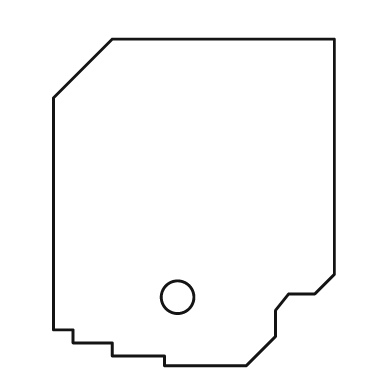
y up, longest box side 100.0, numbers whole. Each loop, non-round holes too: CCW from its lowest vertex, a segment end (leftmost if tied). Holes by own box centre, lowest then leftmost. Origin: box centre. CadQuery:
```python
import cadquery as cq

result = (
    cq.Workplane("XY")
    .moveTo(-9.0, -50.0)
    .lineTo(16.0, -50.0)
    .lineTo(25.0, -41.0)
    .lineTo(25.0, -33.0)
    .lineTo(29.0, -28.0)
    .lineTo(37.0, -28.0)
    .lineTo(43.0, -22.0)
    .lineTo(43.0, 50.0)
    .lineTo(-25.0, 50.0)
    .lineTo(-43.0, 32.0)
    .lineTo(-43.0, -39.0)
    .lineTo(-37.0, -39.0)
    .lineTo(-37.0, -43.0)
    .lineTo(-25.0, -43.0)
    .lineTo(-25.0, -47.0)
    .lineTo(-9.0, -47.0)
    .close()
    .moveTo(-5.0, -29.0)
    .circle(5.0)
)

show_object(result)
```